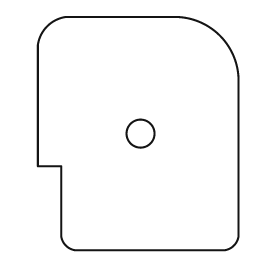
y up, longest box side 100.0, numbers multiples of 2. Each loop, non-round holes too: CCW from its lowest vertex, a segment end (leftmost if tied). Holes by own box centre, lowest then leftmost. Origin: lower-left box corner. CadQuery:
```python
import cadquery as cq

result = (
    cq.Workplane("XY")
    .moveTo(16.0, 0.0)
    .lineTo(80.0, 0.0)
    .threePointArc((84.0, 2.0), (86.0, 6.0))
    .lineTo(86.0, 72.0)
    .threePointArc((78.0, 92.0), (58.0, 100.0))
    .lineTo(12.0, 100.0)
    .threePointArc((4.0, 96.0), (0.0, 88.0))
    .lineTo(0.0, 36.0)
    .lineTo(10.0, 36.0)
    .lineTo(10.0, 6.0)
    .threePointArc((12.0, 2.0), (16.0, 0.0))
    .close()
    .moveTo(44.0, 50.0)
    .circle(6.0)
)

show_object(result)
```